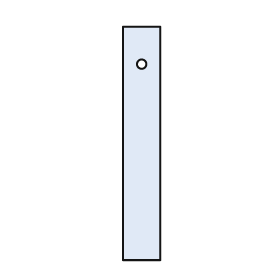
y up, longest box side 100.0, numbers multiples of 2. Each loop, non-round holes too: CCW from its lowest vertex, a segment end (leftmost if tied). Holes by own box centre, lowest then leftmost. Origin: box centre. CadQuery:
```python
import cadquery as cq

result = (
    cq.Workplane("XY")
    .moveTo(-8.0, -50.0)
    .lineTo(8.0, -50.0)
    .lineTo(8.0, 50.0)
    .lineTo(-8.0, 50.0)
    .close()
    .moveTo(0.0, 34.0)
    .circle(2.0)
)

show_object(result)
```